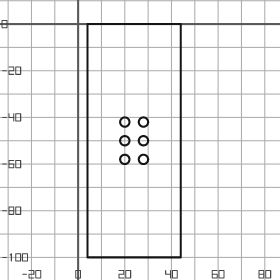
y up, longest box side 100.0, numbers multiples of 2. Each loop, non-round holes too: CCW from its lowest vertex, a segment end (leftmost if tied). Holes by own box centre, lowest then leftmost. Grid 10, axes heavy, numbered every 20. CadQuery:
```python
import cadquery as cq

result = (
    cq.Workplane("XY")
    .moveTo(4.0, -100.0)
    .lineTo(44.0, -100.0)
    .lineTo(44.0, 0.0)
    .lineTo(4.0, 0.0)
    .close()
    .moveTo(20.0, -58.0)
    .circle(2.0)
    .moveTo(28.0, -58.0)
    .circle(2.0)
    .moveTo(20.0, -50.0)
    .circle(2.0)
    .moveTo(28.0, -50.0)
    .circle(2.0)
    .moveTo(20.0, -42.0)
    .circle(2.0)
    .moveTo(28.0, -42.0)
    .circle(2.0)
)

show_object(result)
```